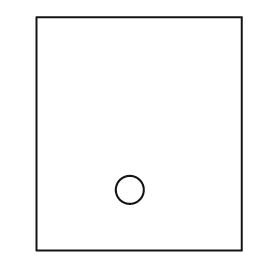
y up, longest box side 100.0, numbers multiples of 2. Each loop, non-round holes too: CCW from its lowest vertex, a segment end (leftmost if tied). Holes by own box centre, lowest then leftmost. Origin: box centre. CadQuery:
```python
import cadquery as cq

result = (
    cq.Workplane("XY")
    .moveTo(-44.0, -50.0)
    .lineTo(44.0, -50.0)
    .lineTo(44.0, 50.0)
    .lineTo(-44.0, 50.0)
    .close()
    .moveTo(-4.0, -24.0)
    .circle(6.0)
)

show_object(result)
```